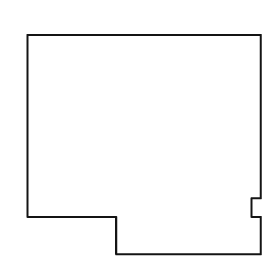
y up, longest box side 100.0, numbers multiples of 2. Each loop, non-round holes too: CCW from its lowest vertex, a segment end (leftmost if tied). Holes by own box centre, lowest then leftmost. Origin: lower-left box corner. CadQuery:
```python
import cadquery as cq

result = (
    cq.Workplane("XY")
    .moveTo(38.0, 0.0)
    .lineTo(100.0, 0.0)
    .lineTo(100.0, 16.0)
    .lineTo(96.0, 16.0)
    .lineTo(96.0, 24.0)
    .lineTo(100.0, 24.0)
    .lineTo(100.0, 94.0)
    .lineTo(0.0, 94.0)
    .lineTo(0.0, 16.0)
    .lineTo(38.0, 16.0)
    .close()
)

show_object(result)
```